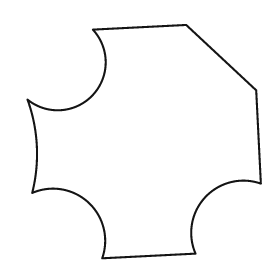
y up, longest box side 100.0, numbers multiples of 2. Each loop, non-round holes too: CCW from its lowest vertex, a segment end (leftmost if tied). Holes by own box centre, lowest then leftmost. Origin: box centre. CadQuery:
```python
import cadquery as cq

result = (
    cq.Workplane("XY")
    .moveTo(-18.0, -50.0)
    .lineTo(22.0, -48.0)
    .threePointArc((26.0, -24.0), (50.0, -18.0))
    .lineTo(48.0, 22.0)
    .lineTo(18.0, 50.0)
    .lineTo(-22.0, 48.0)
    .threePointArc((-22.0, 20.0), (-50.0, 18.0))
    .threePointArc((-46.0, -2.0), (-48.0, -22.0))
    .threePointArc((-24.0, -26.0), (-18.0, -50.0))
    .close()
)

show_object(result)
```